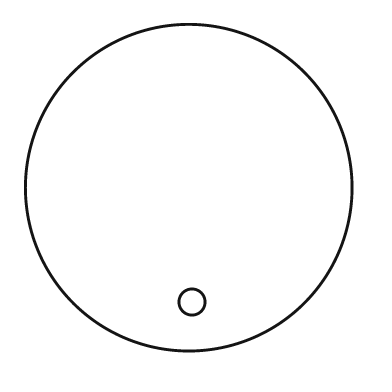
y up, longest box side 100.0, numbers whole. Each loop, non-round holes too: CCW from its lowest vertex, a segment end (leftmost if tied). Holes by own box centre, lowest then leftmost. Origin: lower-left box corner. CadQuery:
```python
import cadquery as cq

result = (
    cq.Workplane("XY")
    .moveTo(50.0, 50.0)
    .circle(50.0)
    .moveTo(51.0, 15.0)
    .circle(4.0)
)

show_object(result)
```